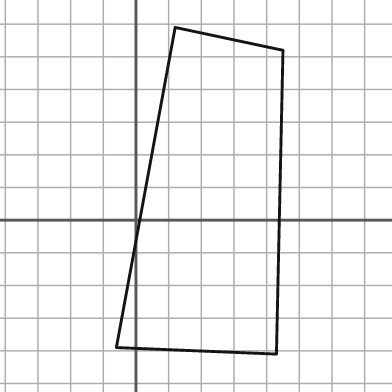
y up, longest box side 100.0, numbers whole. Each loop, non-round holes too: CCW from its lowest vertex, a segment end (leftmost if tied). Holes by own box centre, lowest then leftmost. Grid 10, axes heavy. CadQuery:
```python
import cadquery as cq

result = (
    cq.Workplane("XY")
    .moveTo(43.0, -41.0)
    .lineTo(45.0, 52.0)
    .lineTo(12.0, 59.0)
    .lineTo(-6.0, -39.0)
    .close()
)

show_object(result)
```